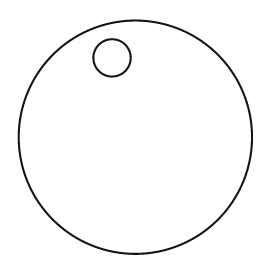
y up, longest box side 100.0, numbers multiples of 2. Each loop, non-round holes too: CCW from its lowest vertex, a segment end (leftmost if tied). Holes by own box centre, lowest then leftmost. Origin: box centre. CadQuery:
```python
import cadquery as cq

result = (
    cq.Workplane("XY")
    .moveTo(0.0, 0.0)
    .circle(50.0)
    .moveTo(-10.0, 34.0)
    .circle(8.0)
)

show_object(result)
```